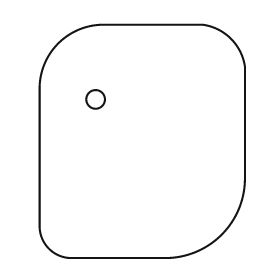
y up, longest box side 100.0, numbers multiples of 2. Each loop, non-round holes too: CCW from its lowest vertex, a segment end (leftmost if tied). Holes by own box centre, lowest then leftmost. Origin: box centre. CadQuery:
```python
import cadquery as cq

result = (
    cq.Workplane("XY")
    .moveTo(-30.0, -50.0)
    .lineTo(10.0, -50.0)
    .threePointArc((34.0, -40.0), (44.0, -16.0))
    .lineTo(44.0, 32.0)
    .threePointArc((38.0, 44.0), (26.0, 50.0))
    .lineTo(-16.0, 50.0)
    .threePointArc((-36.0, 42.0), (-44.0, 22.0))
    .lineTo(-44.0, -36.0)
    .threePointArc((-40.0, -46.0), (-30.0, -50.0))
    .close()
    .moveTo(-20.0, 18.0)
    .circle(4.0)
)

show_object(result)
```